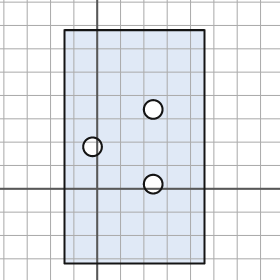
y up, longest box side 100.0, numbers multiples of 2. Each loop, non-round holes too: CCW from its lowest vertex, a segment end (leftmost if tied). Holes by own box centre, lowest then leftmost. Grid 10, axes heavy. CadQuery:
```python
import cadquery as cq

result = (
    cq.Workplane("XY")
    .moveTo(-14.0, -32.0)
    .lineTo(46.0, -32.0)
    .lineTo(46.0, 68.0)
    .lineTo(-14.0, 68.0)
    .close()
    .moveTo(24.0, 2.0)
    .circle(4.0)
    .moveTo(-2.0, 18.0)
    .circle(4.0)
    .moveTo(24.0, 34.0)
    .circle(4.0)
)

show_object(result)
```